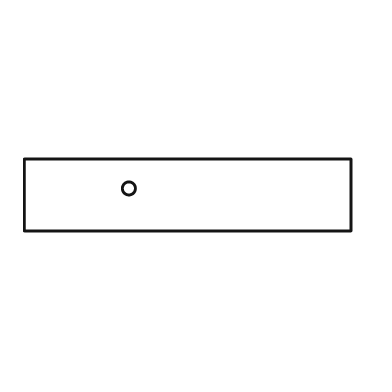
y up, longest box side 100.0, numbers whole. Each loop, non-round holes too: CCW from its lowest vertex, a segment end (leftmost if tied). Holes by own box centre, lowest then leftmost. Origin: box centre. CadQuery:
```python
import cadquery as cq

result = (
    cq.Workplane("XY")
    .moveTo(-50.0, -11.0)
    .lineTo(50.0, -11.0)
    .lineTo(50.0, 11.0)
    .lineTo(-50.0, 11.0)
    .close()
    .moveTo(-18.0, 2.0)
    .circle(2.0)
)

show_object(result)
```